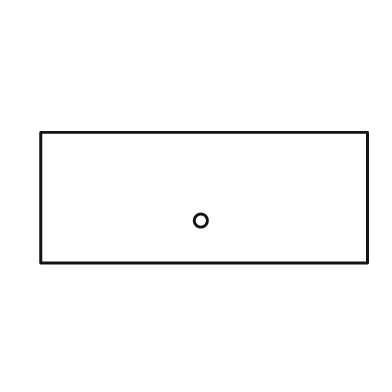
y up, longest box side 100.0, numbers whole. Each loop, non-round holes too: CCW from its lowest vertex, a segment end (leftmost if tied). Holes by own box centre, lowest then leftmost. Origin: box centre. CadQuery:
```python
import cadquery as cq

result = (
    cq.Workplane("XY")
    .moveTo(-50.0, -20.0)
    .lineTo(50.0, -20.0)
    .lineTo(50.0, 20.0)
    .lineTo(-50.0, 20.0)
    .close()
    .moveTo(-1.0, -7.0)
    .circle(2.0)
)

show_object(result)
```